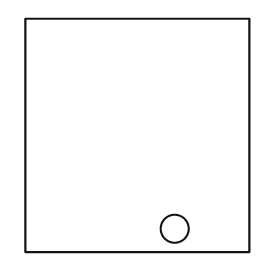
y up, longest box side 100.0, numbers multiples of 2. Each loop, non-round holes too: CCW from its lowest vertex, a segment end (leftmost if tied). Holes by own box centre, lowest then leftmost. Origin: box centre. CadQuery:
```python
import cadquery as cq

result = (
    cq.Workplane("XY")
    .moveTo(-48.0, -50.0)
    .lineTo(48.0, -50.0)
    .lineTo(48.0, 50.0)
    .lineTo(-48.0, 50.0)
    .close()
    .moveTo(16.0, -40.0)
    .circle(6.0)
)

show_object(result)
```